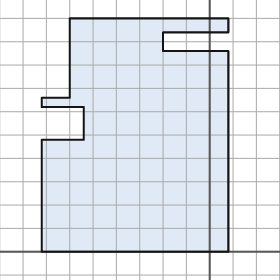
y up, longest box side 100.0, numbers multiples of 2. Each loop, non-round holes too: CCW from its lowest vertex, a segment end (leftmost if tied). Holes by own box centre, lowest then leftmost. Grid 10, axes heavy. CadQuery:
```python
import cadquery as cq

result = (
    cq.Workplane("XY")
    .moveTo(-72.0, 0.0)
    .lineTo(8.0, 0.0)
    .lineTo(8.0, 86.0)
    .lineTo(-20.0, 86.0)
    .lineTo(-20.0, 94.0)
    .lineTo(8.0, 94.0)
    .lineTo(8.0, 100.0)
    .lineTo(-60.0, 100.0)
    .lineTo(-60.0, 66.0)
    .lineTo(-72.0, 66.0)
    .lineTo(-72.0, 62.0)
    .lineTo(-54.0, 62.0)
    .lineTo(-54.0, 48.0)
    .lineTo(-72.0, 48.0)
    .close()
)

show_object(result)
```